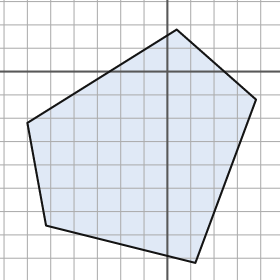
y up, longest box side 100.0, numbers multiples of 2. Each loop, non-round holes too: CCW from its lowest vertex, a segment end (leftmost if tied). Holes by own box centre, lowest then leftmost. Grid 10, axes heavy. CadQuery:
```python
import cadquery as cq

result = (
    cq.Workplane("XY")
    .moveTo(12.0, -82.0)
    .lineTo(38.0, -12.0)
    .lineTo(4.0, 18.0)
    .lineTo(-60.0, -22.0)
    .lineTo(-52.0, -66.0)
    .close()
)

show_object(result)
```